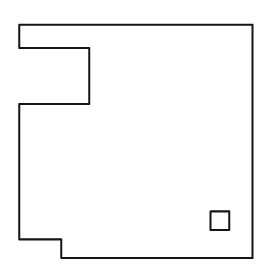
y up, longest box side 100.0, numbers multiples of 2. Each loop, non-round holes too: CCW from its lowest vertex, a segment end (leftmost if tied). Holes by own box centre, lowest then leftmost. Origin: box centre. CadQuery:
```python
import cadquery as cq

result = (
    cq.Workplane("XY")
    .moveTo(-32.0, -50.0)
    .lineTo(50.0, -50.0)
    .lineTo(50.0, 50.0)
    .lineTo(-50.0, 50.0)
    .lineTo(-50.0, 40.0)
    .lineTo(-20.0, 40.0)
    .lineTo(-20.0, 16.0)
    .lineTo(-50.0, 16.0)
    .lineTo(-50.0, -42.0)
    .lineTo(-32.0, -42.0)
    .close()
    .moveTo(32.0, -38.0)
    .lineTo(40.0, -38.0)
    .lineTo(40.0, -30.0)
    .lineTo(32.0, -30.0)
    .close()
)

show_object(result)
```